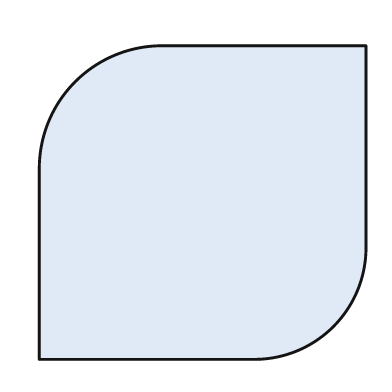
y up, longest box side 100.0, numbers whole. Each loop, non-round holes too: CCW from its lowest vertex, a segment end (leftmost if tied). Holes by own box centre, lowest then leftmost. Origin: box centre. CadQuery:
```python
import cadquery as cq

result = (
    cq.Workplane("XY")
    .moveTo(-50.0, -48.0)
    .lineTo(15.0, -48.0)
    .threePointArc((40.0, -38.0), (50.0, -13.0))
    .lineTo(50.0, 48.0)
    .lineTo(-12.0, 48.0)
    .threePointArc((-39.0, 37.0), (-50.0, 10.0))
    .close()
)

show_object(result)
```